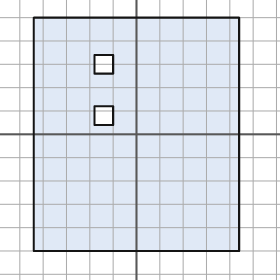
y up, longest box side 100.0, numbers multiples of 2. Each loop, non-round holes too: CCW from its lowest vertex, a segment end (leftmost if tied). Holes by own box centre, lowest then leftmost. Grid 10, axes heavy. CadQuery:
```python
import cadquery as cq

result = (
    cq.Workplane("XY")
    .moveTo(-44.0, -50.0)
    .lineTo(44.0, -50.0)
    .lineTo(44.0, 50.0)
    .lineTo(-44.0, 50.0)
    .close()
    .moveTo(-18.0, 4.0)
    .lineTo(-10.0, 4.0)
    .lineTo(-10.0, 12.0)
    .lineTo(-18.0, 12.0)
    .close()
    .moveTo(-18.0, 26.0)
    .lineTo(-10.0, 26.0)
    .lineTo(-10.0, 34.0)
    .lineTo(-18.0, 34.0)
    .close()
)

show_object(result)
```